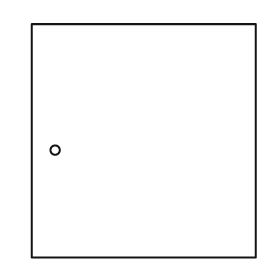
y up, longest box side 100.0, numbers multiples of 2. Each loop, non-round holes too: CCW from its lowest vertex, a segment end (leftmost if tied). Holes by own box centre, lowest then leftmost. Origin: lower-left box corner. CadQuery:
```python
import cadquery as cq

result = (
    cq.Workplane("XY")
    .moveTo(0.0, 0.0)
    .lineTo(96.0, 0.0)
    .lineTo(96.0, 100.0)
    .lineTo(0.0, 100.0)
    .close()
    .moveTo(10.0, 46.0)
    .circle(2.0)
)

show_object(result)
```